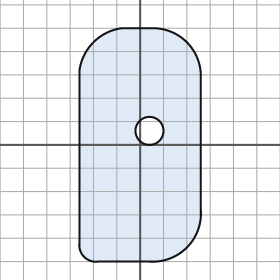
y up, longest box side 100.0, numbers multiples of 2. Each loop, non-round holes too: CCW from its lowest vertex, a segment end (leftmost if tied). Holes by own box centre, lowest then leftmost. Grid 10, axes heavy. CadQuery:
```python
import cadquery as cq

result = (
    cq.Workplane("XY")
    .moveTo(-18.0, -50.0)
    .lineTo(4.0, -50.0)
    .threePointArc((20.0, -44.0), (26.0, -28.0))
    .lineTo(26.0, 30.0)
    .threePointArc((20.0, 44.0), (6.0, 50.0))
    .lineTo(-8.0, 50.0)
    .threePointArc((-20.0, 44.0), (-26.0, 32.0))
    .lineTo(-26.0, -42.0)
    .threePointArc((-24.0, -48.0), (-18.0, -50.0))
    .close()
    .moveTo(4.0, 6.0)
    .circle(6.0)
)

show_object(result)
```